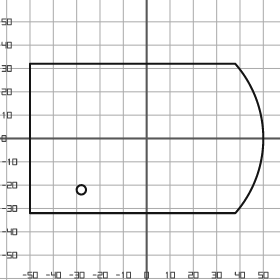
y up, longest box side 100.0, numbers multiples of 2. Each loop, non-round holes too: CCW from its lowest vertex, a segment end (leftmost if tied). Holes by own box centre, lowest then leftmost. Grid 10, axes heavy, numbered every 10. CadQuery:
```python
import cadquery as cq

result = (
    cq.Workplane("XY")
    .moveTo(-50.0, -32.0)
    .lineTo(38.0, -32.0)
    .threePointArc((50.0, 0.0), (38.0, 32.0))
    .lineTo(-50.0, 32.0)
    .close()
    .moveTo(-28.0, -22.0)
    .circle(2.0)
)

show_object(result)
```